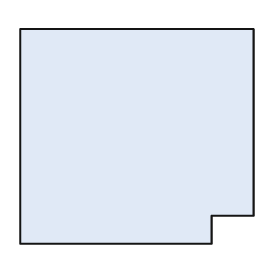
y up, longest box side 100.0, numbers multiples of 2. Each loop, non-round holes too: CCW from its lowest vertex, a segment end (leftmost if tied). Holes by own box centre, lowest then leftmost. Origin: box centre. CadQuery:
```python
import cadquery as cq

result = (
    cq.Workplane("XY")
    .moveTo(-50.0, -46.0)
    .lineTo(32.0, -46.0)
    .lineTo(32.0, -34.0)
    .lineTo(50.0, -34.0)
    .lineTo(50.0, 46.0)
    .lineTo(-50.0, 46.0)
    .close()
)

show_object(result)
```